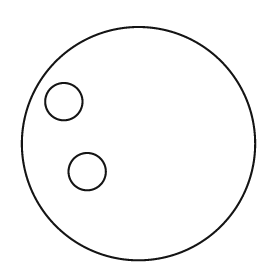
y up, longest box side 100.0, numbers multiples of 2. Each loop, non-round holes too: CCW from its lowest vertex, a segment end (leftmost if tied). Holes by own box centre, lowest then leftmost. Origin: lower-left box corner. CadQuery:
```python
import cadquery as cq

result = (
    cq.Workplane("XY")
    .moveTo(50.0, 50.0)
    .circle(50.0)
    .moveTo(28.0, 38.0)
    .circle(8.0)
    .moveTo(18.0, 68.0)
    .circle(8.0)
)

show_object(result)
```